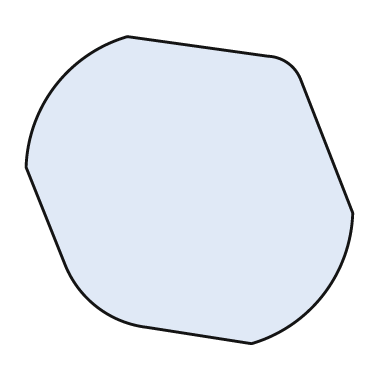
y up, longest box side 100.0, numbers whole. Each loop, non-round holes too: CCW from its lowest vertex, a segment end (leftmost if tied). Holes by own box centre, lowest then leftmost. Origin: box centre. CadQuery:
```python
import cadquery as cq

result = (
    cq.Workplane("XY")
    .moveTo(19.0, -47.0)
    .threePointArc((41.0, -32.0), (50.0, -7.0))
    .lineTo(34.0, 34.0)
    .threePointArc((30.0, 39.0), (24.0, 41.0))
    .lineTo(-19.0, 47.0)
    .threePointArc((-41.0, 32.0), (-50.0, 7.0))
    .lineTo(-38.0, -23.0)
    .threePointArc((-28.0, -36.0), (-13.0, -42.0))
    .close()
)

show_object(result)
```